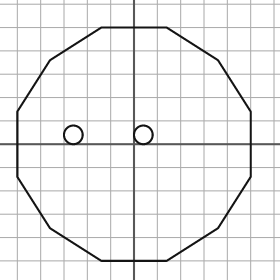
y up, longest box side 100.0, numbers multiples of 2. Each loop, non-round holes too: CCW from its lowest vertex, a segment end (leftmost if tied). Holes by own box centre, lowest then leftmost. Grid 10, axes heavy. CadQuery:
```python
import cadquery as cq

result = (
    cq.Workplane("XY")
    .moveTo(-14.0, -50.0)
    .lineTo(14.0, -50.0)
    .lineTo(36.0, -36.0)
    .lineTo(50.0, -14.0)
    .lineTo(50.0, 14.0)
    .lineTo(36.0, 36.0)
    .lineTo(14.0, 50.0)
    .lineTo(-14.0, 50.0)
    .lineTo(-36.0, 36.0)
    .lineTo(-50.0, 14.0)
    .lineTo(-50.0, -14.0)
    .lineTo(-36.0, -36.0)
    .close()
    .moveTo(-26.0, 4.0)
    .circle(4.0)
    .moveTo(4.0, 4.0)
    .circle(4.0)
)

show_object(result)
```